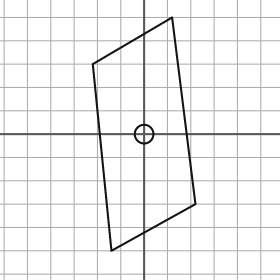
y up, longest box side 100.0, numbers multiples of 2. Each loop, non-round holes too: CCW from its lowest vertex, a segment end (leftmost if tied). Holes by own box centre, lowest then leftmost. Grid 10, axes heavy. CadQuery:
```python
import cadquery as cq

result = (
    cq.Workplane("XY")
    .moveTo(-14.0, -50.0)
    .lineTo(22.0, -30.0)
    .lineTo(12.0, 50.0)
    .lineTo(-22.0, 30.0)
    .close()
    .moveTo(0.0, 0.0)
    .circle(4.0)
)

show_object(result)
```